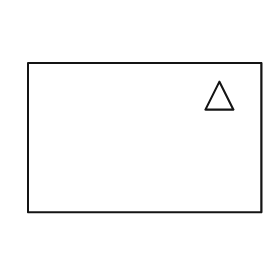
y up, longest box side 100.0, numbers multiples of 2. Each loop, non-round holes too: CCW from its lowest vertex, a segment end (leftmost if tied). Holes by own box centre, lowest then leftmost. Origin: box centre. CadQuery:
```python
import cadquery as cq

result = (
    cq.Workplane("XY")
    .moveTo(-50.0, -32.0)
    .lineTo(50.0, -32.0)
    .lineTo(50.0, 32.0)
    .lineTo(-50.0, 32.0)
    .close()
    .moveTo(26.0, 12.0)
    .lineTo(38.0, 12.0)
    .lineTo(32.0, 24.0)
    .close()
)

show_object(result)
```